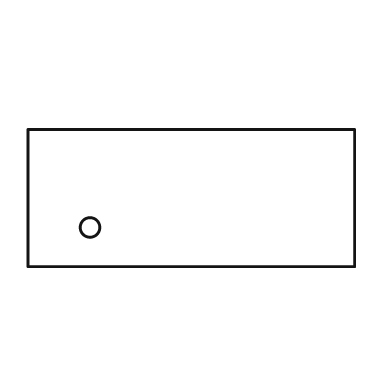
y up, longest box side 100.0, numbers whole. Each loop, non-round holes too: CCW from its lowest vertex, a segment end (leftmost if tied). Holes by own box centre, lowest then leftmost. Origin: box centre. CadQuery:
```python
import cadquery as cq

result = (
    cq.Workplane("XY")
    .moveTo(-50.0, -21.0)
    .lineTo(50.0, -21.0)
    .lineTo(50.0, 21.0)
    .lineTo(-50.0, 21.0)
    .close()
    .moveTo(-31.0, -9.0)
    .circle(3.0)
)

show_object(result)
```